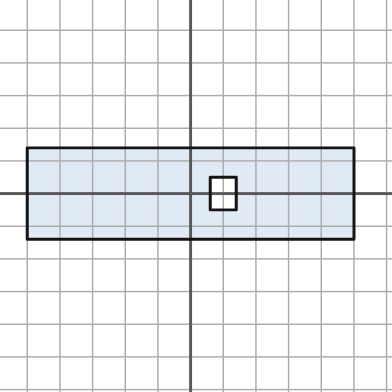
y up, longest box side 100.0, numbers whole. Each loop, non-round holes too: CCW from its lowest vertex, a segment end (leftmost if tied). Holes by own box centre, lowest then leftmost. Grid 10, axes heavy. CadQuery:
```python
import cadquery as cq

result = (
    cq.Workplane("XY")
    .moveTo(-50.0, -14.0)
    .lineTo(50.0, -14.0)
    .lineTo(50.0, 14.0)
    .lineTo(-50.0, 14.0)
    .close()
    .moveTo(6.0, -5.0)
    .lineTo(14.0, -5.0)
    .lineTo(14.0, 5.0)
    .lineTo(6.0, 5.0)
    .close()
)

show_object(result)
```